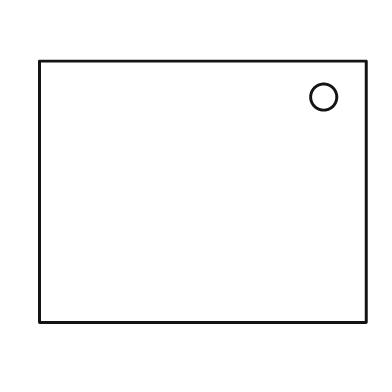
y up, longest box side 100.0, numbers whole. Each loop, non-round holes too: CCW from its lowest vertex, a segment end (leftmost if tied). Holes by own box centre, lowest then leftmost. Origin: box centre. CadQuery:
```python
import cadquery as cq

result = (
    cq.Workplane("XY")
    .moveTo(-50.0, -40.0)
    .lineTo(50.0, -40.0)
    .lineTo(50.0, 40.0)
    .lineTo(-50.0, 40.0)
    .close()
    .moveTo(37.0, 29.0)
    .circle(4.0)
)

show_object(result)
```